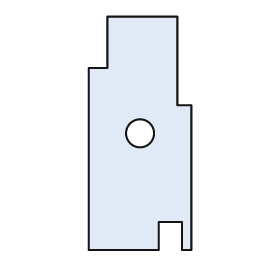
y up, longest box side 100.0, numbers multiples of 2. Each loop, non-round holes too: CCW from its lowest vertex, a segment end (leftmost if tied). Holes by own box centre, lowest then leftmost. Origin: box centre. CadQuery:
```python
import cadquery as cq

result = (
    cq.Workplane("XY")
    .moveTo(-22.0, -50.0)
    .lineTo(8.0, -50.0)
    .lineTo(8.0, -38.0)
    .lineTo(18.0, -38.0)
    .lineTo(18.0, -50.0)
    .lineTo(22.0, -50.0)
    .lineTo(22.0, 12.0)
    .lineTo(16.0, 12.0)
    .lineTo(16.0, 50.0)
    .lineTo(-14.0, 50.0)
    .lineTo(-14.0, 28.0)
    .lineTo(-22.0, 28.0)
    .close()
    .moveTo(0.0, 0.0)
    .circle(6.0)
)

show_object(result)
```